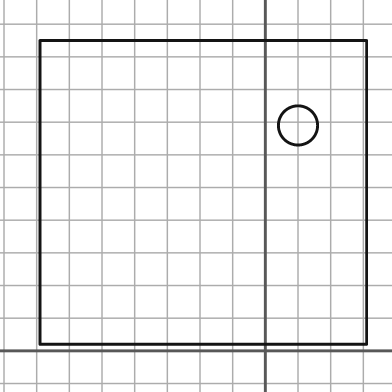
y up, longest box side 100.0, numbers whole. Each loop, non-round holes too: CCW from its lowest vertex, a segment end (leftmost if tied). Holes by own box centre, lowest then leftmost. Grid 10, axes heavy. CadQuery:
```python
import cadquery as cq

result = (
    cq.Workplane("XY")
    .moveTo(-69.0, 2.0)
    .lineTo(31.0, 2.0)
    .lineTo(31.0, 95.0)
    .lineTo(-69.0, 95.0)
    .close()
    .moveTo(10.0, 69.0)
    .circle(6.0)
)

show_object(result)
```